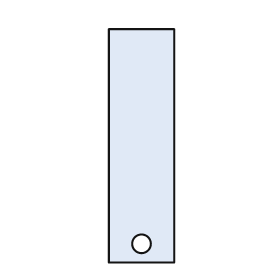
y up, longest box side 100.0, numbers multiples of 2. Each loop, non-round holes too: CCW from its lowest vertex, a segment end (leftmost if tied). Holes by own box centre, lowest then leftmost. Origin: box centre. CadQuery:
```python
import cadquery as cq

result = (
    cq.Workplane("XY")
    .moveTo(-14.0, -50.0)
    .lineTo(14.0, -50.0)
    .lineTo(14.0, 50.0)
    .lineTo(-14.0, 50.0)
    .close()
    .moveTo(0.0, -42.0)
    .circle(4.0)
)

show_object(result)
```